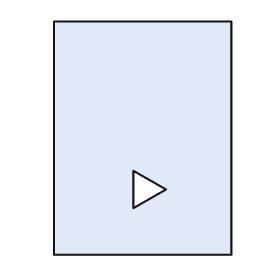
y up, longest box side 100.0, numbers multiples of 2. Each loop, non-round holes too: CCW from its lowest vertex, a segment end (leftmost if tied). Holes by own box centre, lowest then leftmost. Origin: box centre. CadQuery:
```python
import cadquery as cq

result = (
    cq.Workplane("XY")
    .moveTo(-38.0, -50.0)
    .lineTo(38.0, -50.0)
    .lineTo(38.0, 50.0)
    .lineTo(-38.0, 50.0)
    .close()
    .moveTo(-4.0, -30.0)
    .lineTo(10.0, -22.0)
    .lineTo(-4.0, -14.0)
    .close()
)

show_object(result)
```